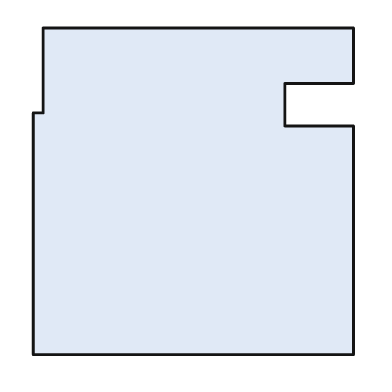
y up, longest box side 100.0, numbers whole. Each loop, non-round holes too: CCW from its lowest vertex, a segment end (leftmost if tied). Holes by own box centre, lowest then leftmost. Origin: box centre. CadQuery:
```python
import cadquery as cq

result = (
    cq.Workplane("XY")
    .moveTo(-49.0, -50.0)
    .lineTo(49.0, -50.0)
    .lineTo(49.0, 20.0)
    .lineTo(28.0, 20.0)
    .lineTo(28.0, 33.0)
    .lineTo(49.0, 33.0)
    .lineTo(49.0, 50.0)
    .lineTo(-46.0, 50.0)
    .lineTo(-46.0, 24.0)
    .lineTo(-49.0, 24.0)
    .close()
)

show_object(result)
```